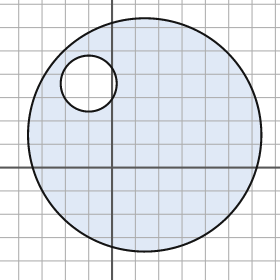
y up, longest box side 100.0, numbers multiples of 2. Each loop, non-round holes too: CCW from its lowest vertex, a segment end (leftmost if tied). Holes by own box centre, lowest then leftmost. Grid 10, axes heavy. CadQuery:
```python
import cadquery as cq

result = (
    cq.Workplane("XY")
    .moveTo(14.0, 14.0)
    .circle(50.0)
    .moveTo(-10.0, 36.0)
    .circle(12.0)
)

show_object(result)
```